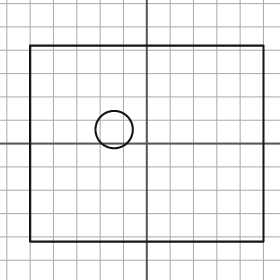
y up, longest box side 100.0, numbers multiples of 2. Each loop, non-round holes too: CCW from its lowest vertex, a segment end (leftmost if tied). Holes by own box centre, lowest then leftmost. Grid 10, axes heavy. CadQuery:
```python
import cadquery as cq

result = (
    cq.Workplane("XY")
    .moveTo(-50.0, -42.0)
    .lineTo(50.0, -42.0)
    .lineTo(50.0, 42.0)
    .lineTo(-50.0, 42.0)
    .close()
    .moveTo(-14.0, 6.0)
    .circle(8.0)
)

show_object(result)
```